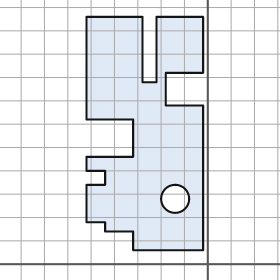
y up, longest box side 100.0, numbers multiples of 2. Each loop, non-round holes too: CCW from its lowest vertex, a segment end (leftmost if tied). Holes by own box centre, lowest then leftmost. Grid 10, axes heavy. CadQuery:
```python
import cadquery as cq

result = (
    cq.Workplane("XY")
    .moveTo(-32.0, 6.0)
    .lineTo(-2.0, 6.0)
    .lineTo(-2.0, 68.0)
    .lineTo(-18.0, 68.0)
    .lineTo(-18.0, 82.0)
    .lineTo(-2.0, 82.0)
    .lineTo(-2.0, 106.0)
    .lineTo(-22.0, 106.0)
    .lineTo(-22.0, 78.0)
    .lineTo(-28.0, 78.0)
    .lineTo(-28.0, 106.0)
    .lineTo(-52.0, 106.0)
    .lineTo(-52.0, 62.0)
    .lineTo(-32.0, 62.0)
    .lineTo(-32.0, 46.0)
    .lineTo(-52.0, 46.0)
    .lineTo(-52.0, 40.0)
    .lineTo(-44.0, 40.0)
    .lineTo(-44.0, 34.0)
    .lineTo(-52.0, 34.0)
    .lineTo(-52.0, 18.0)
    .lineTo(-44.0, 18.0)
    .lineTo(-44.0, 14.0)
    .lineTo(-32.0, 14.0)
    .close()
    .moveTo(-14.0, 28.0)
    .circle(6.0)
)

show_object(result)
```